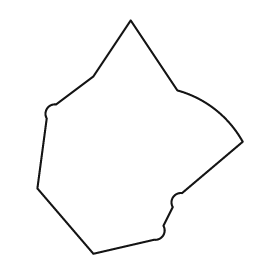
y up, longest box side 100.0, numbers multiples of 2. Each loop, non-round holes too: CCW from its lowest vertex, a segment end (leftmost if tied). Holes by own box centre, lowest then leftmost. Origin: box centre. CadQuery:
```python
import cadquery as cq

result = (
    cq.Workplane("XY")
    .moveTo(-20.0, -50.0)
    .lineTo(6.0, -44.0)
    .threePointArc((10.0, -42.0), (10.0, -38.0))
    .lineTo(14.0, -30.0)
    .threePointArc((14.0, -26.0), (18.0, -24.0))
    .lineTo(44.0, -2.0)
    .threePointArc((32.0, 12.0), (16.0, 20.0))
    .lineTo(-4.0, 50.0)
    .lineTo(-20.0, 26.0)
    .lineTo(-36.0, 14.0)
    .threePointArc((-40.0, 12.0), (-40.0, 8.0))
    .lineTo(-44.0, -22.0)
    .close()
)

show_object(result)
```